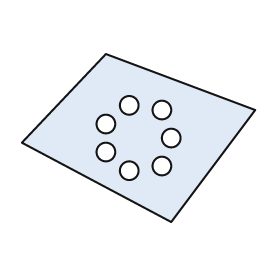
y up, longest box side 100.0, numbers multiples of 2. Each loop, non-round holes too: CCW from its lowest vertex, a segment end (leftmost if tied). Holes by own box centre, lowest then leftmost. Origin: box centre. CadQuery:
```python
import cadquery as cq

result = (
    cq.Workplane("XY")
    .moveTo(14.0, -36.0)
    .lineTo(50.0, 12.0)
    .lineTo(-14.0, 36.0)
    .lineTo(-50.0, -2.0)
    .close()
    .moveTo(-4.0, -14.0)
    .circle(4.0)
    .moveTo(10.0, -12.0)
    .circle(4.0)
    .moveTo(-14.0, -6.0)
    .circle(4.0)
    .moveTo(14.0, 0.0)
    .circle(4.0)
    .moveTo(-14.0, 6.0)
    .circle(4.0)
    .moveTo(10.0, 12.0)
    .circle(4.0)
    .moveTo(-4.0, 14.0)
    .circle(4.0)
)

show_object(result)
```